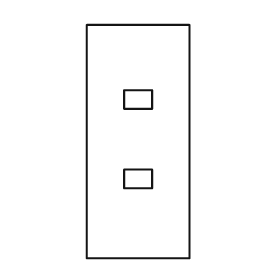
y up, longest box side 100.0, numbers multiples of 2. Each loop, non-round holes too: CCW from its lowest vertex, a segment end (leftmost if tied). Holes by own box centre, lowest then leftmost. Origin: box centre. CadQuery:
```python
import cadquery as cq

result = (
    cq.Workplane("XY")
    .moveTo(-22.0, -50.0)
    .lineTo(22.0, -50.0)
    .lineTo(22.0, 50.0)
    .lineTo(-22.0, 50.0)
    .close()
    .moveTo(-6.0, -20.0)
    .lineTo(6.0, -20.0)
    .lineTo(6.0, -12.0)
    .lineTo(-6.0, -12.0)
    .close()
    .moveTo(-6.0, 14.0)
    .lineTo(6.0, 14.0)
    .lineTo(6.0, 22.0)
    .lineTo(-6.0, 22.0)
    .close()
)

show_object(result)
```